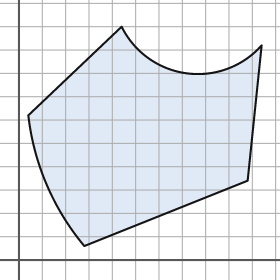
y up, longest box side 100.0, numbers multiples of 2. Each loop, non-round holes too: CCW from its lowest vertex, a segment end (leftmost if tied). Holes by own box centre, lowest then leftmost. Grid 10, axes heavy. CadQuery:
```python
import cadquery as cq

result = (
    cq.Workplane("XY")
    .moveTo(28.0, 6.0)
    .lineTo(98.0, 34.0)
    .lineTo(104.0, 92.0)
    .threePointArc((72.0, 80.0), (44.0, 100.0))
    .lineTo(4.0, 62.0)
    .threePointArc((12.0, 32.0), (28.0, 6.0))
    .close()
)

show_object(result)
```